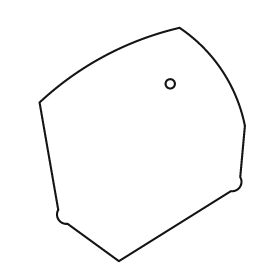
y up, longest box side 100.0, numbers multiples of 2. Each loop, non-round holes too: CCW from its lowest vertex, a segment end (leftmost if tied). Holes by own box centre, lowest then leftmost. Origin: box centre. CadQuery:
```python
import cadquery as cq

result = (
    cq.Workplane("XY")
    .moveTo(-10.0, -50.0)
    .lineTo(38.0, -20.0)
    .threePointArc((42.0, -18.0), (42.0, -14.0))
    .lineTo(44.0, 8.0)
    .threePointArc((34.0, 32.0), (16.0, 50.0))
    .threePointArc((-16.0, 38.0), (-44.0, 18.0))
    .lineTo(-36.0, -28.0)
    .threePointArc((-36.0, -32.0), (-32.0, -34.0))
    .close()
    .moveTo(12.0, 26.0)
    .circle(2.0)
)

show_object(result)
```